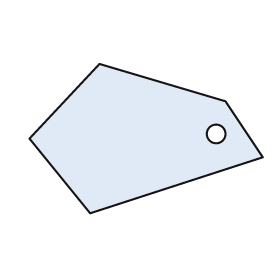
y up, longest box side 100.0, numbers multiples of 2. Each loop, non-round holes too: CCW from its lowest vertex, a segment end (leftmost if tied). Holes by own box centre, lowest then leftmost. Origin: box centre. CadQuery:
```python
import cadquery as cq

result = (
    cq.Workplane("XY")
    .moveTo(-24.0, -32.0)
    .lineTo(50.0, -8.0)
    .lineTo(34.0, 16.0)
    .lineTo(-20.0, 32.0)
    .lineTo(-50.0, 0.0)
    .close()
    .moveTo(30.0, 2.0)
    .circle(4.0)
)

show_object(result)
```